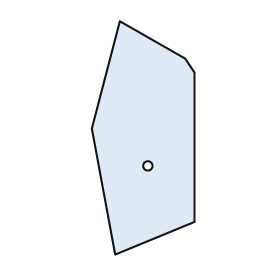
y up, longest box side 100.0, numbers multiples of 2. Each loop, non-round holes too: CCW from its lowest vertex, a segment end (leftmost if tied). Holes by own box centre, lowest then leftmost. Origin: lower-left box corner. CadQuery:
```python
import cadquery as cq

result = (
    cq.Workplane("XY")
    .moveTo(10.0, 0.0)
    .lineTo(44.0, 14.0)
    .lineTo(44.0, 78.0)
    .lineTo(40.0, 84.0)
    .lineTo(12.0, 100.0)
    .lineTo(0.0, 54.0)
    .close()
    .moveTo(24.0, 38.0)
    .circle(2.0)
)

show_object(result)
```